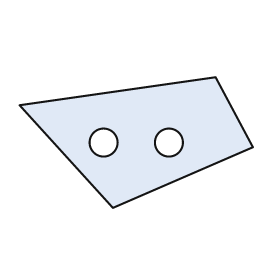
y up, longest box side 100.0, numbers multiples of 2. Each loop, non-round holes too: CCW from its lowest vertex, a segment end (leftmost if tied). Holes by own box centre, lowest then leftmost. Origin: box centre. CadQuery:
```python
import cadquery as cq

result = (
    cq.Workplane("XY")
    .moveTo(-10.0, -28.0)
    .lineTo(50.0, -2.0)
    .lineTo(34.0, 28.0)
    .lineTo(-50.0, 16.0)
    .close()
    .moveTo(-14.0, 0.0)
    .circle(6.0)
    .moveTo(14.0, 0.0)
    .circle(6.0)
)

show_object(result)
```